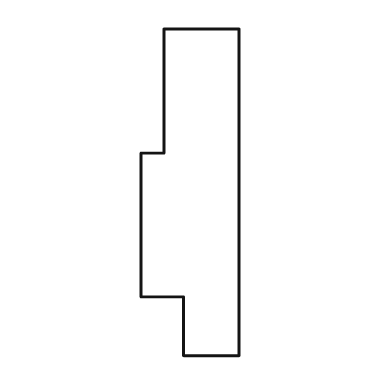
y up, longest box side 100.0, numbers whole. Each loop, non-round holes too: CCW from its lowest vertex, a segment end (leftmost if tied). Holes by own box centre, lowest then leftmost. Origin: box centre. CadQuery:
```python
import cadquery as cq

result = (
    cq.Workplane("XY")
    .moveTo(-2.0, -50.0)
    .lineTo(15.0, -50.0)
    .lineTo(15.0, 50.0)
    .lineTo(-8.0, 50.0)
    .lineTo(-8.0, 12.0)
    .lineTo(-15.0, 12.0)
    .lineTo(-15.0, -32.0)
    .lineTo(-2.0, -32.0)
    .close()
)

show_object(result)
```